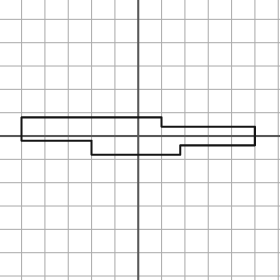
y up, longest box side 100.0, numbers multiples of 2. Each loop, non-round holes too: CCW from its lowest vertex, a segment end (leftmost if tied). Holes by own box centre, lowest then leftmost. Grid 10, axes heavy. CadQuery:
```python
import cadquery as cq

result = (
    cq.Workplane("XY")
    .moveTo(-20.0, -8.0)
    .lineTo(18.0, -8.0)
    .lineTo(18.0, -4.0)
    .lineTo(50.0, -4.0)
    .lineTo(50.0, 4.0)
    .lineTo(10.0, 4.0)
    .lineTo(10.0, 8.0)
    .lineTo(-50.0, 8.0)
    .lineTo(-50.0, -2.0)
    .lineTo(-20.0, -2.0)
    .close()
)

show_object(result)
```